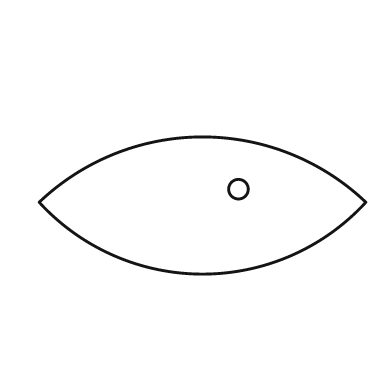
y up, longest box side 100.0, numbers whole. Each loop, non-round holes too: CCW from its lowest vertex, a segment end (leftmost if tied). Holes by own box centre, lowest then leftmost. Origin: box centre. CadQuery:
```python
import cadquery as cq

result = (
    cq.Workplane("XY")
    .moveTo(-50.0, 1.0)
    .threePointArc((0.0, -21.0), (50.0, 1.0))
    .threePointArc((0.0, 21.0), (-50.0, 1.0))
    .close()
    .moveTo(11.0, 5.0)
    .circle(3.0)
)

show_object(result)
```